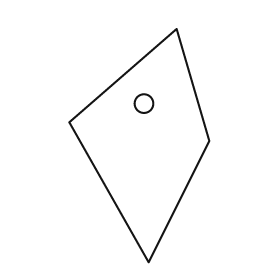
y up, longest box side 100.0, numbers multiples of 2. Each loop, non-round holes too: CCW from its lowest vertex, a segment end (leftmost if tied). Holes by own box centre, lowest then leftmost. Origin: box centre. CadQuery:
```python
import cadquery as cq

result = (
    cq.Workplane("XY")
    .moveTo(4.0, -50.0)
    .lineTo(30.0, 2.0)
    .lineTo(16.0, 50.0)
    .lineTo(-30.0, 10.0)
    .close()
    .moveTo(2.0, 18.0)
    .circle(4.0)
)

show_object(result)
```